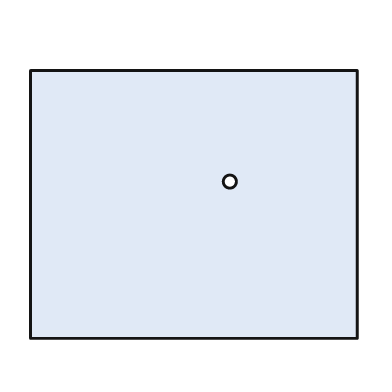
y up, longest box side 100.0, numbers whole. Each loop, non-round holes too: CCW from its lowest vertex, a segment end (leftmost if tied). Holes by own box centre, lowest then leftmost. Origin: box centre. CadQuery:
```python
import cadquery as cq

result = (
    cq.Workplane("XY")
    .moveTo(-50.0, -41.0)
    .lineTo(50.0, -41.0)
    .lineTo(50.0, 41.0)
    .lineTo(-50.0, 41.0)
    .close()
    .moveTo(11.0, 7.0)
    .circle(2.0)
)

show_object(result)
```